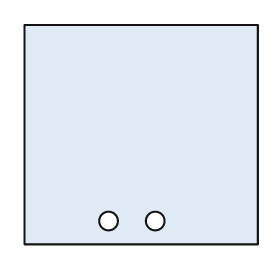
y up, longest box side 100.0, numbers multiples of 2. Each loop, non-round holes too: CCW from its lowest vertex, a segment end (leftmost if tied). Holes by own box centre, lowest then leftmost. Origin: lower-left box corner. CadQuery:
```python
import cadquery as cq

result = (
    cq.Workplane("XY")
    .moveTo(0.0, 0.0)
    .lineTo(100.0, 0.0)
    .lineTo(100.0, 94.0)
    .lineTo(0.0, 94.0)
    .close()
    .moveTo(36.0, 10.0)
    .circle(4.0)
    .moveTo(56.0, 10.0)
    .circle(4.0)
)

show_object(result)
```